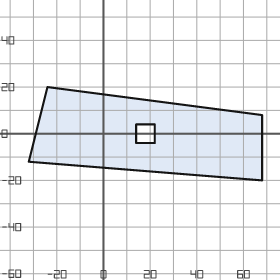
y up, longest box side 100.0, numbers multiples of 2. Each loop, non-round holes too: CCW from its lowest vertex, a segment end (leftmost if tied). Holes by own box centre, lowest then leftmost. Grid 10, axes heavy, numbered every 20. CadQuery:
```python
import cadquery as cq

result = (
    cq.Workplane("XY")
    .moveTo(68.0, -20.0)
    .lineTo(68.0, 8.0)
    .lineTo(-24.0, 20.0)
    .lineTo(-32.0, -12.0)
    .close()
    .moveTo(14.0, -4.0)
    .lineTo(22.0, -4.0)
    .lineTo(22.0, 4.0)
    .lineTo(14.0, 4.0)
    .close()
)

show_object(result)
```